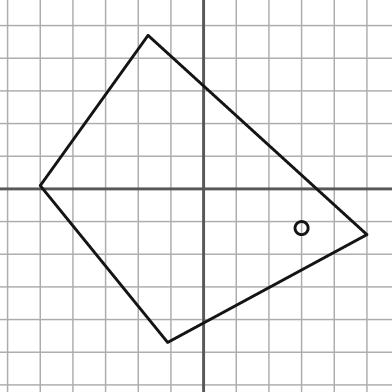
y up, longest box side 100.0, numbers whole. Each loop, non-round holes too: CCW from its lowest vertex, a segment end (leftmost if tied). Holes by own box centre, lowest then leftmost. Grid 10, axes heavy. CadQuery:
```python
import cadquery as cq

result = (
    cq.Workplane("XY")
    .moveTo(-11.0, -47.0)
    .lineTo(50.0, -14.0)
    .lineTo(-17.0, 47.0)
    .lineTo(-50.0, 1.0)
    .close()
    .moveTo(30.0, -12.0)
    .circle(2.0)
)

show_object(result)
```